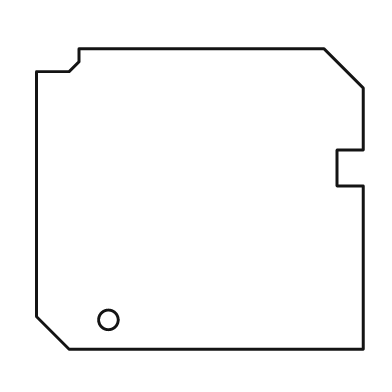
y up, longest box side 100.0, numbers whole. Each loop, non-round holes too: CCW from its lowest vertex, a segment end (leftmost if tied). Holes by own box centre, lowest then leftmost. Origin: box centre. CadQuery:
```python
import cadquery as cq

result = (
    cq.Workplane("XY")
    .moveTo(-40.0, -46.0)
    .lineTo(50.0, -46.0)
    .lineTo(50.0, 4.0)
    .lineTo(42.0, 4.0)
    .lineTo(42.0, 15.0)
    .lineTo(50.0, 15.0)
    .lineTo(50.0, 34.0)
    .lineTo(38.0, 46.0)
    .lineTo(-37.0, 46.0)
    .lineTo(-37.0, 42.0)
    .lineTo(-40.0, 39.0)
    .lineTo(-50.0, 39.0)
    .lineTo(-50.0, -36.0)
    .close()
    .moveTo(-28.0, -37.0)
    .circle(3.0)
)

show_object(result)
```